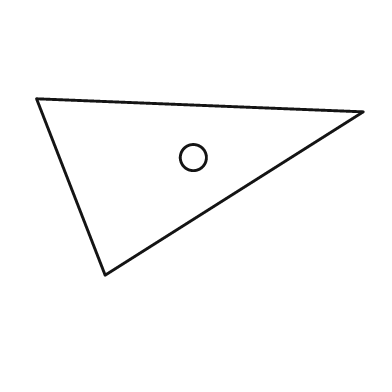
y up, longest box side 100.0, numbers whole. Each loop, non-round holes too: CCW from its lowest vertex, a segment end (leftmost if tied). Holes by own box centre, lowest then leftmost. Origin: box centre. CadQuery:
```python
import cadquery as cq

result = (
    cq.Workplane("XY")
    .moveTo(-29.0, -27.0)
    .lineTo(50.0, 23.0)
    .lineTo(-50.0, 27.0)
    .close()
    .moveTo(-2.0, 9.0)
    .circle(4.0)
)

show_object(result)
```